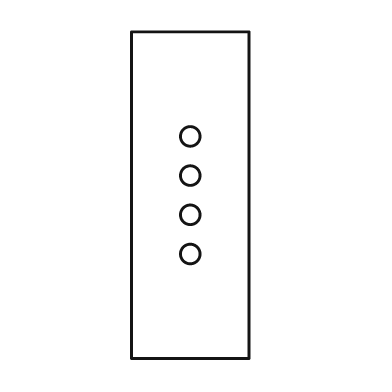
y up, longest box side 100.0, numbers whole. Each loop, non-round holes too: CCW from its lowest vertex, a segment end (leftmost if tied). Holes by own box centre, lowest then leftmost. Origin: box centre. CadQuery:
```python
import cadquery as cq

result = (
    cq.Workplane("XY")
    .moveTo(-18.0, -50.0)
    .lineTo(18.0, -50.0)
    .lineTo(18.0, 50.0)
    .lineTo(-18.0, 50.0)
    .close()
    .moveTo(0.0, -18.0)
    .circle(3.0)
    .moveTo(0.0, -6.0)
    .circle(3.0)
    .moveTo(0.0, 6.0)
    .circle(3.0)
    .moveTo(0.0, 18.0)
    .circle(3.0)
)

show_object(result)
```